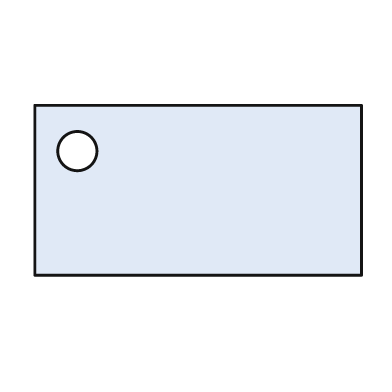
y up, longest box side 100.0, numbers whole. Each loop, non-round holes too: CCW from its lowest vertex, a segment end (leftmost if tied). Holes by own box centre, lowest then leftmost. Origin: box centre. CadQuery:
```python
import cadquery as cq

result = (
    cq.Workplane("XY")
    .moveTo(-50.0, -26.0)
    .lineTo(50.0, -26.0)
    .lineTo(50.0, 26.0)
    .lineTo(-50.0, 26.0)
    .close()
    .moveTo(-37.0, 12.0)
    .circle(6.0)
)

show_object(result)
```